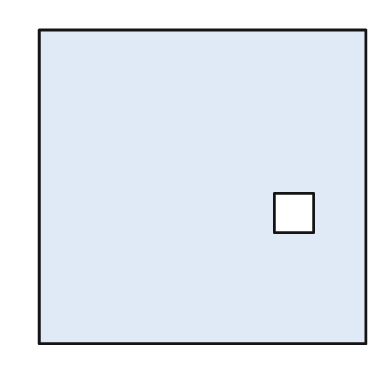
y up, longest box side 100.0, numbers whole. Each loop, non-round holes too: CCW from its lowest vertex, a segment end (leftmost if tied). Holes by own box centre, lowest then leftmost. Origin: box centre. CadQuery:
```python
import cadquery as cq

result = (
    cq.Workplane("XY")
    .moveTo(-50.0, -48.0)
    .lineTo(50.0, -48.0)
    .lineTo(50.0, 48.0)
    .lineTo(-50.0, 48.0)
    .close()
    .moveTo(22.0, -14.0)
    .lineTo(34.0, -14.0)
    .lineTo(34.0, -2.0)
    .lineTo(22.0, -2.0)
    .close()
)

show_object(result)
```